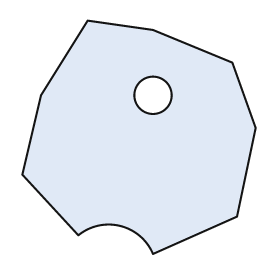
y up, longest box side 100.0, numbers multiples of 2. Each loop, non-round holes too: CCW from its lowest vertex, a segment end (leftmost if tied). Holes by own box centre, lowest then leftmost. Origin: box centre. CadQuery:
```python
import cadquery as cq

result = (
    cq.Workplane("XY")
    .moveTo(6.0, -50.0)
    .lineTo(42.0, -34.0)
    .lineTo(50.0, 4.0)
    .lineTo(40.0, 32.0)
    .lineTo(6.0, 46.0)
    .lineTo(-22.0, 50.0)
    .lineTo(-42.0, 18.0)
    .lineTo(-50.0, -16.0)
    .lineTo(-26.0, -42.0)
    .threePointArc((-8.0, -38.0), (6.0, -50.0))
    .close()
    .moveTo(6.0, 18.0)
    .circle(8.0)
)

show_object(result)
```